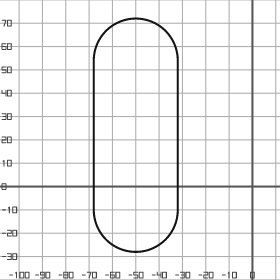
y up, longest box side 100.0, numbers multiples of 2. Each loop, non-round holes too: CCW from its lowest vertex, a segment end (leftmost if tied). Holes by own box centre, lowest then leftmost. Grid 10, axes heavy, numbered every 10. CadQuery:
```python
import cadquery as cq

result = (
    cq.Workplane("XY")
    .moveTo(-68.0, -10.0)
    .threePointArc((-50.0, -28.0), (-32.0, -10.0))
    .lineTo(-32.0, 54.0)
    .threePointArc((-50.0, 72.0), (-68.0, 54.0))
    .close()
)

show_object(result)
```